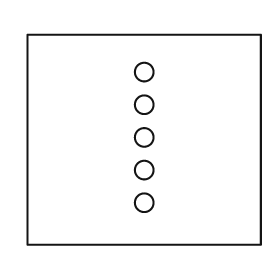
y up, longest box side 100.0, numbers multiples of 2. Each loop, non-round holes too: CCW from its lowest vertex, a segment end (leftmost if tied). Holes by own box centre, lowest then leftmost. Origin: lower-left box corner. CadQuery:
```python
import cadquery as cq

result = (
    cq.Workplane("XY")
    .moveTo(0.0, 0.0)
    .lineTo(100.0, 0.0)
    .lineTo(100.0, 90.0)
    .lineTo(0.0, 90.0)
    .close()
    .moveTo(50.0, 18.0)
    .circle(4.0)
    .moveTo(50.0, 32.0)
    .circle(4.0)
    .moveTo(50.0, 46.0)
    .circle(4.0)
    .moveTo(50.0, 60.0)
    .circle(4.0)
    .moveTo(50.0, 74.0)
    .circle(4.0)
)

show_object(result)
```